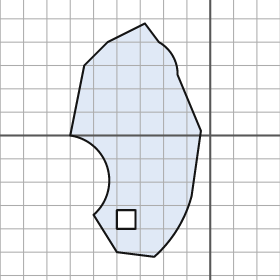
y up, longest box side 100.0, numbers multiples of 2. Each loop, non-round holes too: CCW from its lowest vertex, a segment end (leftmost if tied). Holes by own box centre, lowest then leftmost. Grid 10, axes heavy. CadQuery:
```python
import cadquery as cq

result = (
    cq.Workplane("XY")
    .moveTo(-24.0, -52.0)
    .threePointArc((-14.0, -40.0), (-8.0, -26.0))
    .lineTo(-4.0, 2.0)
    .lineTo(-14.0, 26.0)
    .threePointArc((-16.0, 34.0), (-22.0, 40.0))
    .lineTo(-28.0, 48.0)
    .lineTo(-44.0, 40.0)
    .lineTo(-54.0, 30.0)
    .lineTo(-60.0, 0.0)
    .threePointArc((-44.0, -14.0), (-50.0, -34.0))
    .lineTo(-40.0, -50.0)
    .close()
    .moveTo(-40.0, -40.0)
    .lineTo(-32.0, -40.0)
    .lineTo(-32.0, -32.0)
    .lineTo(-40.0, -32.0)
    .close()
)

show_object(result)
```